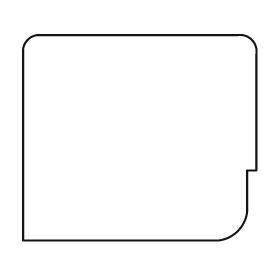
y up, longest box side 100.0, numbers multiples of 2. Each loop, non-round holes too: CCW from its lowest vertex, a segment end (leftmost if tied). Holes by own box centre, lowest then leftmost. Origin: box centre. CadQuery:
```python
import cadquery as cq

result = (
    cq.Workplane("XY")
    .moveTo(-50.0, -44.0)
    .lineTo(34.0, -44.0)
    .threePointArc((42.0, -40.0), (46.0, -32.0))
    .lineTo(46.0, -14.0)
    .lineTo(50.0, -14.0)
    .lineTo(50.0, 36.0)
    .threePointArc((48.0, 42.0), (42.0, 44.0))
    .lineTo(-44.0, 44.0)
    .threePointArc((-48.0, 42.0), (-50.0, 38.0))
    .close()
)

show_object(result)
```